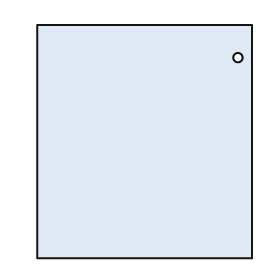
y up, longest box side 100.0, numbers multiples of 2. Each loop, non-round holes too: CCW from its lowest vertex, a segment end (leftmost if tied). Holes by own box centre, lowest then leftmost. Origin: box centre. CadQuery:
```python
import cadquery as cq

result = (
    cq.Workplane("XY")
    .moveTo(-46.0, -50.0)
    .lineTo(46.0, -50.0)
    .lineTo(46.0, 50.0)
    .lineTo(-46.0, 50.0)
    .close()
    .moveTo(40.0, 36.0)
    .circle(2.0)
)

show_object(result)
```